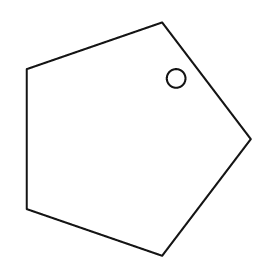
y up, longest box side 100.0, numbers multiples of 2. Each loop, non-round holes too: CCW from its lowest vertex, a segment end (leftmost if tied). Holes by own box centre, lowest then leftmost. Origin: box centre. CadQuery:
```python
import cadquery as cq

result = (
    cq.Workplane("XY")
    .moveTo(10.0, -50.0)
    .lineTo(48.0, 0.0)
    .lineTo(10.0, 50.0)
    .lineTo(-48.0, 30.0)
    .lineTo(-48.0, -30.0)
    .close()
    .moveTo(16.0, 26.0)
    .circle(4.0)
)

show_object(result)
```